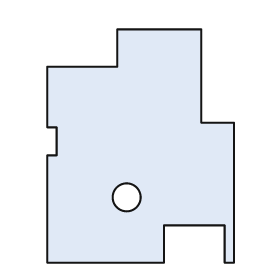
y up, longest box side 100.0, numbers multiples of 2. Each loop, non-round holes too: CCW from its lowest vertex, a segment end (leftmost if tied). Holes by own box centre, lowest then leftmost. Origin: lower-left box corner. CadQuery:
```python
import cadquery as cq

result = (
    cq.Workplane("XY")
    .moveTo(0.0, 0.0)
    .lineTo(50.0, 0.0)
    .lineTo(50.0, 16.0)
    .lineTo(76.0, 16.0)
    .lineTo(76.0, 0.0)
    .lineTo(80.0, 0.0)
    .lineTo(80.0, 60.0)
    .lineTo(66.0, 60.0)
    .lineTo(66.0, 100.0)
    .lineTo(30.0, 100.0)
    .lineTo(30.0, 84.0)
    .lineTo(0.0, 84.0)
    .lineTo(0.0, 58.0)
    .lineTo(4.0, 58.0)
    .lineTo(4.0, 46.0)
    .lineTo(0.0, 46.0)
    .close()
    .moveTo(34.0, 28.0)
    .circle(6.0)
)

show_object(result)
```